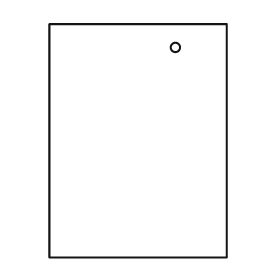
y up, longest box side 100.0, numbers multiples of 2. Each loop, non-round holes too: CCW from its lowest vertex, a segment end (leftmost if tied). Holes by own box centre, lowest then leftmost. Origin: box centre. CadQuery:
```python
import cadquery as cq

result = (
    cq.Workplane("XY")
    .moveTo(-38.0, -50.0)
    .lineTo(38.0, -50.0)
    .lineTo(38.0, 50.0)
    .lineTo(-38.0, 50.0)
    .close()
    .moveTo(16.0, 40.0)
    .circle(2.0)
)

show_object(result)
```